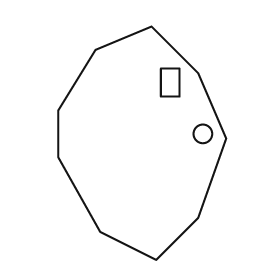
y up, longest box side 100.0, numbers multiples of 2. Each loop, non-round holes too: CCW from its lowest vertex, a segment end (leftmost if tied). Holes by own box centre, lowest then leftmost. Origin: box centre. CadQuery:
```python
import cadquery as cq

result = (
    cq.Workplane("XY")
    .moveTo(6.0, -50.0)
    .lineTo(24.0, -32.0)
    .lineTo(36.0, 2.0)
    .lineTo(24.0, 30.0)
    .lineTo(4.0, 50.0)
    .lineTo(-20.0, 40.0)
    .lineTo(-36.0, 14.0)
    .lineTo(-36.0, -6.0)
    .lineTo(-18.0, -38.0)
    .close()
    .moveTo(26.0, 4.0)
    .circle(4.0)
    .moveTo(8.0, 20.0)
    .lineTo(16.0, 20.0)
    .lineTo(16.0, 32.0)
    .lineTo(8.0, 32.0)
    .close()
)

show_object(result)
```